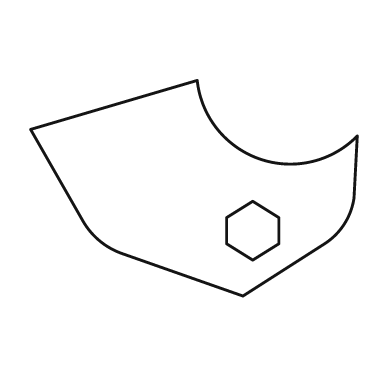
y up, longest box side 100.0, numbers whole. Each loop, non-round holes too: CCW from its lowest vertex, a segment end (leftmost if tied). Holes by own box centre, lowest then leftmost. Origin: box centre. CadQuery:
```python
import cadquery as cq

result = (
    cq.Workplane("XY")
    .moveTo(15.0, -33.0)
    .lineTo(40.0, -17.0)
    .threePointArc((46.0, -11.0), (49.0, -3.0))
    .lineTo(50.0, 16.0)
    .threePointArc((20.0, 9.0), (1.0, 33.0))
    .lineTo(-50.0, 18.0)
    .lineTo(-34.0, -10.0)
    .threePointArc((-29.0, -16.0), (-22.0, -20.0))
    .close()
    .moveTo(18.0, -22.0)
    .lineTo(26.0, -17.0)
    .lineTo(26.0, -9.0)
    .lineTo(18.0, -4.0)
    .lineTo(10.0, -9.0)
    .lineTo(10.0, -17.0)
    .close()
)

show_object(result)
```